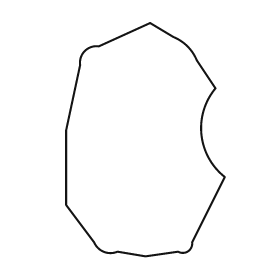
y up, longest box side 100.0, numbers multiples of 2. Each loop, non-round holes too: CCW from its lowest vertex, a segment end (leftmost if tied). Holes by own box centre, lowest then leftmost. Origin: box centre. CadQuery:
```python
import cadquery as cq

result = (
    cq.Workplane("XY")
    .moveTo(0.0, -50.0)
    .lineTo(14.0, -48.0)
    .threePointArc((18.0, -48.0), (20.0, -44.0))
    .lineTo(34.0, -16.0)
    .threePointArc((24.0, 2.0), (30.0, 22.0))
    .lineTo(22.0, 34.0)
    .threePointArc((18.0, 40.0), (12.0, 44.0))
    .lineTo(2.0, 50.0)
    .lineTo(-20.0, 40.0)
    .threePointArc((-26.0, 38.0), (-28.0, 32.0))
    .lineTo(-34.0, 4.0)
    .lineTo(-34.0, -28.0)
    .lineTo(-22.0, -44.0)
    .threePointArc((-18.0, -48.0), (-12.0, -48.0))
    .close()
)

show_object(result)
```